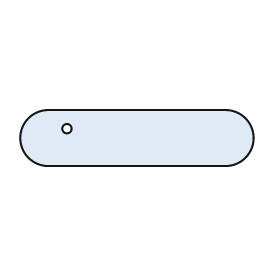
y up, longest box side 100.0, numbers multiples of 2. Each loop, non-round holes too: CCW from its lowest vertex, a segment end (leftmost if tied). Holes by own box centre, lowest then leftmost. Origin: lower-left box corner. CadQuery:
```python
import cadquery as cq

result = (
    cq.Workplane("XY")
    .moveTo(12.0, 0.0)
    .lineTo(88.0, 0.0)
    .threePointArc((100.0, 12.0), (88.0, 24.0))
    .lineTo(12.0, 24.0)
    .threePointArc((0.0, 12.0), (12.0, 0.0))
    .close()
    .moveTo(20.0, 16.0)
    .circle(2.0)
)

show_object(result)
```